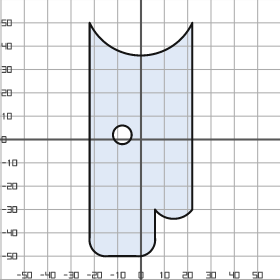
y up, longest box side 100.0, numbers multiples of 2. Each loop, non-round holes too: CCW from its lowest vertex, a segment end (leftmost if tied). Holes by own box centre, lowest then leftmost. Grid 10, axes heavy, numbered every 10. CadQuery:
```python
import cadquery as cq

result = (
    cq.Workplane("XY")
    .moveTo(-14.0, -50.0)
    .lineTo(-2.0, -50.0)
    .threePointArc((4.0, -48.0), (6.0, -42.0))
    .lineTo(6.0, -30.0)
    .threePointArc((14.0, -34.0), (22.0, -30.0))
    .lineTo(22.0, 50.0)
    .threePointArc((0.0, 36.0), (-22.0, 50.0))
    .lineTo(-22.0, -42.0)
    .threePointArc((-20.0, -48.0), (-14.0, -50.0))
    .close()
    .moveTo(-8.0, 2.0)
    .circle(4.0)
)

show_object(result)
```